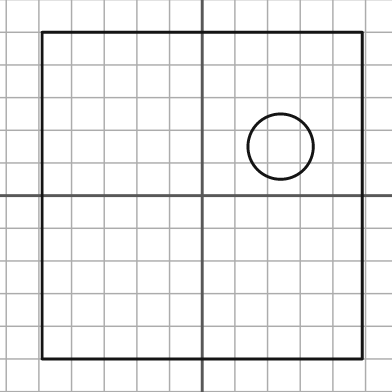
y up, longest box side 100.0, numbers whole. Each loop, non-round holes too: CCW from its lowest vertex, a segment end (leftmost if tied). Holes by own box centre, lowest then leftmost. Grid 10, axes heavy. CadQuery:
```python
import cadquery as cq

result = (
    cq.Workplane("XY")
    .moveTo(-49.0, -50.0)
    .lineTo(49.0, -50.0)
    .lineTo(49.0, 50.0)
    .lineTo(-49.0, 50.0)
    .close()
    .moveTo(24.0, 15.0)
    .circle(10.0)
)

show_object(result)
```